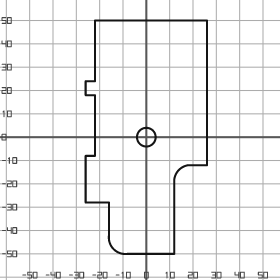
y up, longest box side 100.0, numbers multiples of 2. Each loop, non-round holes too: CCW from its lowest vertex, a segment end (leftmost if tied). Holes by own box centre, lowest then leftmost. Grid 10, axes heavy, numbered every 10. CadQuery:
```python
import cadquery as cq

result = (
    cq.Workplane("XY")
    .moveTo(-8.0, -50.0)
    .lineTo(12.0, -50.0)
    .lineTo(12.0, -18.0)
    .threePointArc((14.0, -14.0), (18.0, -12.0))
    .lineTo(26.0, -12.0)
    .lineTo(26.0, 50.0)
    .lineTo(-22.0, 50.0)
    .lineTo(-22.0, 24.0)
    .lineTo(-26.0, 24.0)
    .lineTo(-26.0, 18.0)
    .lineTo(-22.0, 18.0)
    .lineTo(-22.0, -8.0)
    .lineTo(-26.0, -8.0)
    .lineTo(-26.0, -28.0)
    .lineTo(-16.0, -28.0)
    .lineTo(-16.0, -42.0)
    .threePointArc((-14.0, -48.0), (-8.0, -50.0))
    .close()
    .moveTo(0.0, 0.0)
    .circle(4.0)
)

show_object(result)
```